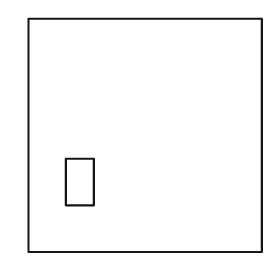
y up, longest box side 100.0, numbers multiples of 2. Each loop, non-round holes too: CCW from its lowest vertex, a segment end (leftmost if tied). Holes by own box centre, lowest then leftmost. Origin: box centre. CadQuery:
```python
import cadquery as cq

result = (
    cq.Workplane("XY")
    .moveTo(-50.0, -50.0)
    .lineTo(50.0, -50.0)
    .lineTo(50.0, 50.0)
    .lineTo(-50.0, 50.0)
    .close()
    .moveTo(-34.0, -30.0)
    .lineTo(-22.0, -30.0)
    .lineTo(-22.0, -10.0)
    .lineTo(-34.0, -10.0)
    .close()
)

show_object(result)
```